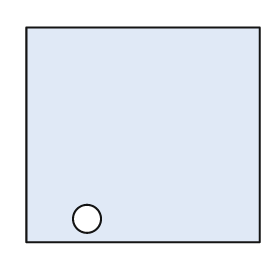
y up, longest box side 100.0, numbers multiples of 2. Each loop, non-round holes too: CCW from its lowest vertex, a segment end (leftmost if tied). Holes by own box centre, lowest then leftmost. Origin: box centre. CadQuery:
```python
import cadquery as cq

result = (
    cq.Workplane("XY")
    .moveTo(-50.0, -46.0)
    .lineTo(50.0, -46.0)
    .lineTo(50.0, 46.0)
    .lineTo(-50.0, 46.0)
    .close()
    .moveTo(-24.0, -36.0)
    .circle(6.0)
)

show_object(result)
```